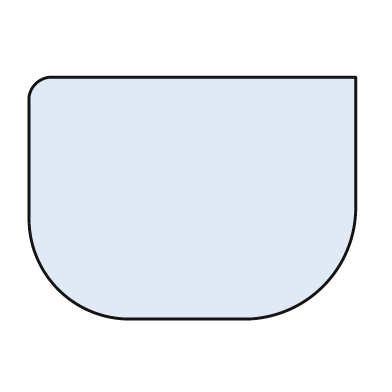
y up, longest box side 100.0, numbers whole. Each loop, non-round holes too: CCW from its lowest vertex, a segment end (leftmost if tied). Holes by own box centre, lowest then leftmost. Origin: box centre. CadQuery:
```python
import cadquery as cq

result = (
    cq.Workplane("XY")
    .moveTo(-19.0, -37.0)
    .lineTo(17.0, -37.0)
    .threePointArc((40.0, -27.0), (50.0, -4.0))
    .lineTo(50.0, 37.0)
    .lineTo(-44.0, 37.0)
    .threePointArc((-48.0, 35.0), (-50.0, 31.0))
    .lineTo(-50.0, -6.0)
    .threePointArc((-41.0, -28.0), (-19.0, -37.0))
    .close()
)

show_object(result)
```